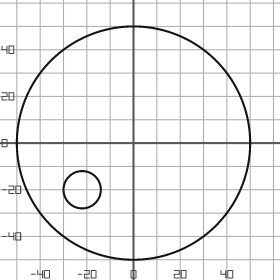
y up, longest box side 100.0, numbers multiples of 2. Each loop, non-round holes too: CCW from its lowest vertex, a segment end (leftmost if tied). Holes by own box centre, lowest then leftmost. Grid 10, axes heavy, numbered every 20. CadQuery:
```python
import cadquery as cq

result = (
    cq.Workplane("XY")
    .moveTo(0.0, 0.0)
    .circle(50.0)
    .moveTo(-22.0, -20.0)
    .circle(8.0)
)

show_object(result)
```